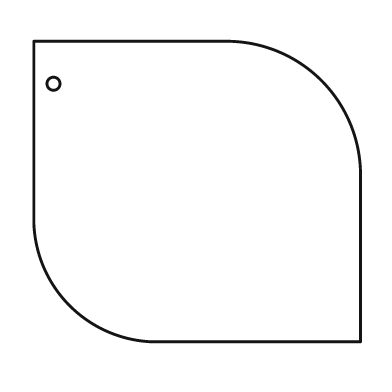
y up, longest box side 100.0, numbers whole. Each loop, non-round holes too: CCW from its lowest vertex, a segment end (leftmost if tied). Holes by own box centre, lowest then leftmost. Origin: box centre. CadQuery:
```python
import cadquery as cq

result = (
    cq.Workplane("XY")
    .moveTo(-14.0, -46.0)
    .lineTo(50.0, -46.0)
    .lineTo(50.0, 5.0)
    .threePointArc((38.0, 34.0), (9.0, 46.0))
    .lineTo(-50.0, 46.0)
    .lineTo(-50.0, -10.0)
    .threePointArc((-39.0, -35.0), (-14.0, -46.0))
    .close()
    .moveTo(-44.0, 33.0)
    .circle(2.0)
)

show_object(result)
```